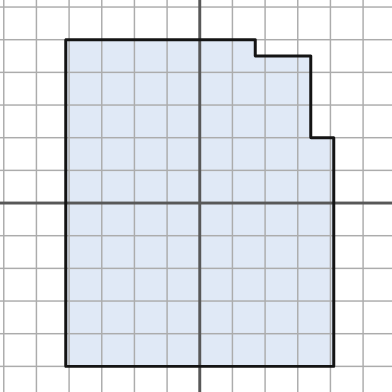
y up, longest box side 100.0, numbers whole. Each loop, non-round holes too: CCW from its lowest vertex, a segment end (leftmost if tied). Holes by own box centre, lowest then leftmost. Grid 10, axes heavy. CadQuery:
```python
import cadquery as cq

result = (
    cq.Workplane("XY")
    .moveTo(-41.0, -50.0)
    .lineTo(41.0, -50.0)
    .lineTo(41.0, 20.0)
    .lineTo(34.0, 20.0)
    .lineTo(34.0, 45.0)
    .lineTo(17.0, 45.0)
    .lineTo(17.0, 50.0)
    .lineTo(-41.0, 50.0)
    .close()
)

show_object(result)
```